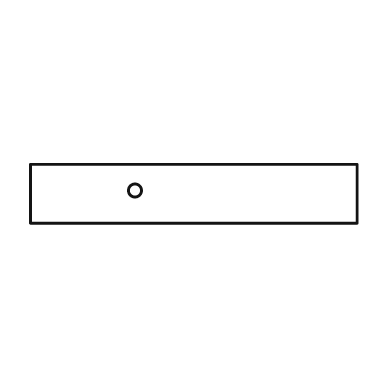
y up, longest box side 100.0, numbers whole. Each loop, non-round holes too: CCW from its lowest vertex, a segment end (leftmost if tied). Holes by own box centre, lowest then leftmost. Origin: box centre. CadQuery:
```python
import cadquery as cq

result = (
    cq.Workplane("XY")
    .moveTo(-50.0, -9.0)
    .lineTo(50.0, -9.0)
    .lineTo(50.0, 9.0)
    .lineTo(-50.0, 9.0)
    .close()
    .moveTo(-18.0, 1.0)
    .circle(2.0)
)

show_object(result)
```